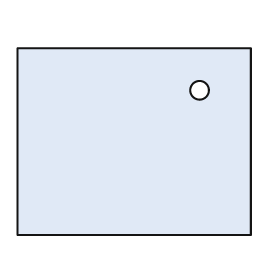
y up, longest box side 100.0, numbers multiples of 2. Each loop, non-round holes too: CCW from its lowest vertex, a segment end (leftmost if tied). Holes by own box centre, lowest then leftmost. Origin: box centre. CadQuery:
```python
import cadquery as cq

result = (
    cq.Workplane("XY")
    .moveTo(-50.0, -40.0)
    .lineTo(50.0, -40.0)
    .lineTo(50.0, 40.0)
    .lineTo(-50.0, 40.0)
    .close()
    .moveTo(28.0, 22.0)
    .circle(4.0)
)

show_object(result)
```